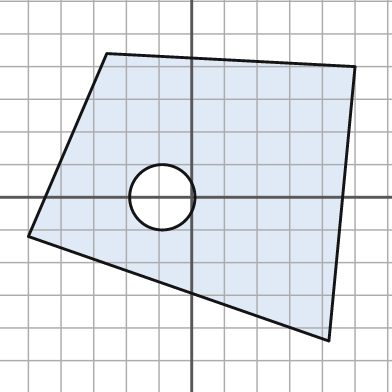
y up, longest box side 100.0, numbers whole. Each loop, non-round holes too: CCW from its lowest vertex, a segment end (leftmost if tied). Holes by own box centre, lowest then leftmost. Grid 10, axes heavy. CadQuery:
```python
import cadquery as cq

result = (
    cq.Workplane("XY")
    .moveTo(42.0, -44.0)
    .lineTo(50.0, 40.0)
    .lineTo(-26.0, 44.0)
    .lineTo(-50.0, -12.0)
    .close()
    .moveTo(-9.0, 0.0)
    .circle(10.0)
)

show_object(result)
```